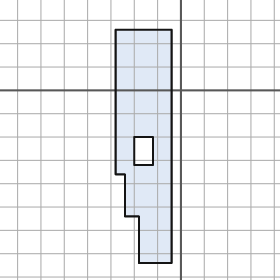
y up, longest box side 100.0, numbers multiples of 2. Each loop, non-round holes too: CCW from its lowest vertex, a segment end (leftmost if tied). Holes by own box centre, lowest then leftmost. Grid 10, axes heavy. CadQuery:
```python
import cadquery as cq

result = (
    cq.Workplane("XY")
    .moveTo(-18.0, -74.0)
    .lineTo(-4.0, -74.0)
    .lineTo(-4.0, 26.0)
    .lineTo(-28.0, 26.0)
    .lineTo(-28.0, -36.0)
    .lineTo(-24.0, -36.0)
    .lineTo(-24.0, -54.0)
    .lineTo(-18.0, -54.0)
    .close()
    .moveTo(-20.0, -32.0)
    .lineTo(-12.0, -32.0)
    .lineTo(-12.0, -20.0)
    .lineTo(-20.0, -20.0)
    .close()
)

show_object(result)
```